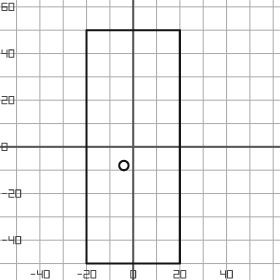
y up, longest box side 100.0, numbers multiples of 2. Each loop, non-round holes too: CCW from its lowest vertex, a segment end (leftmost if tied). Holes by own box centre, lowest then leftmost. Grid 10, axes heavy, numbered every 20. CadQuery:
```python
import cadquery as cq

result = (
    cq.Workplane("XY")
    .moveTo(-20.0, -50.0)
    .lineTo(20.0, -50.0)
    .lineTo(20.0, 50.0)
    .lineTo(-20.0, 50.0)
    .close()
    .moveTo(-4.0, -8.0)
    .circle(2.0)
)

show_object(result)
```